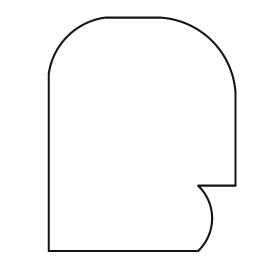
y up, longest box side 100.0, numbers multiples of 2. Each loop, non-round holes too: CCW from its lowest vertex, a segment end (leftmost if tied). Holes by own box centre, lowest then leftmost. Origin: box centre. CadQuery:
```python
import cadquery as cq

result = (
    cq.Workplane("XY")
    .moveTo(-40.0, -50.0)
    .lineTo(24.0, -50.0)
    .threePointArc((30.0, -36.0), (24.0, -22.0))
    .lineTo(40.0, -22.0)
    .lineTo(40.0, 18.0)
    .threePointArc((30.0, 40.0), (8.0, 50.0))
    .lineTo(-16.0, 50.0)
    .threePointArc((-32.0, 42.0), (-40.0, 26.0))
    .close()
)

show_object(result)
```